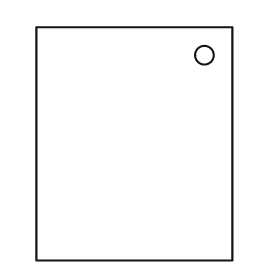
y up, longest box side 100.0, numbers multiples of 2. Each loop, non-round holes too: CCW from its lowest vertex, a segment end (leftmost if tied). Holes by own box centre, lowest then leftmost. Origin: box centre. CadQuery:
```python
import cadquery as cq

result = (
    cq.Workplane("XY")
    .moveTo(-42.0, -50.0)
    .lineTo(42.0, -50.0)
    .lineTo(42.0, 50.0)
    .lineTo(-42.0, 50.0)
    .close()
    .moveTo(30.0, 38.0)
    .circle(4.0)
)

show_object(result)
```